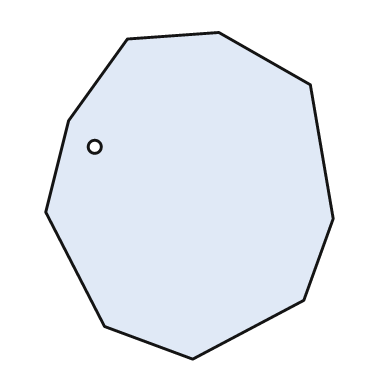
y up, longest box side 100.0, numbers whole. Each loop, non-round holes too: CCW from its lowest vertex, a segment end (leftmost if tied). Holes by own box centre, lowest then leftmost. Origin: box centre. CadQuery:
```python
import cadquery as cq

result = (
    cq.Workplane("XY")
    .moveTo(1.0, -50.0)
    .lineTo(35.0, -32.0)
    .lineTo(44.0, -7.0)
    .lineTo(37.0, 34.0)
    .lineTo(9.0, 50.0)
    .lineTo(-19.0, 48.0)
    .lineTo(-37.0, 23.0)
    .lineTo(-44.0, -5.0)
    .lineTo(-26.0, -40.0)
    .close()
    .moveTo(-29.0, 15.0)
    .circle(2.0)
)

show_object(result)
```